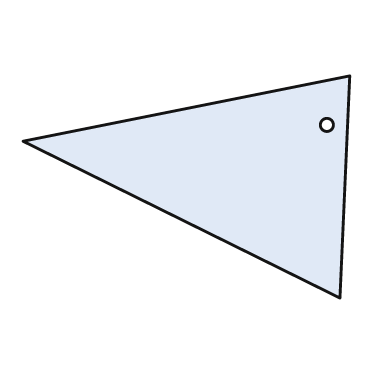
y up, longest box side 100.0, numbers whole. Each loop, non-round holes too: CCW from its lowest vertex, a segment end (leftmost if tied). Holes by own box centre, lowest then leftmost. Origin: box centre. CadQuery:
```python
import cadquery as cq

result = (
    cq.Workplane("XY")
    .moveTo(47.0, -34.0)
    .lineTo(50.0, 34.0)
    .lineTo(-50.0, 14.0)
    .close()
    .moveTo(43.0, 19.0)
    .circle(2.0)
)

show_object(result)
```